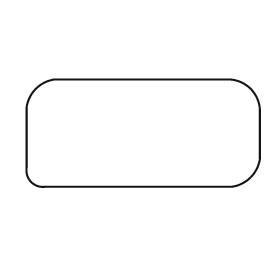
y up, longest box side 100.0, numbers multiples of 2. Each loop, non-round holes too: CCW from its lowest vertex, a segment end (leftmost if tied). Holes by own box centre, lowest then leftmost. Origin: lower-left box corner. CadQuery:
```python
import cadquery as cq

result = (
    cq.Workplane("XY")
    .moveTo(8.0, 0.0)
    .lineTo(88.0, 0.0)
    .threePointArc((96.0, 4.0), (100.0, 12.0))
    .lineTo(100.0, 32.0)
    .threePointArc((96.0, 42.0), (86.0, 46.0))
    .lineTo(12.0, 46.0)
    .threePointArc((4.0, 42.0), (0.0, 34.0))
    .lineTo(0.0, 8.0)
    .threePointArc((2.0, 2.0), (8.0, 0.0))
    .close()
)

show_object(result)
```